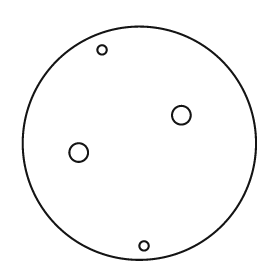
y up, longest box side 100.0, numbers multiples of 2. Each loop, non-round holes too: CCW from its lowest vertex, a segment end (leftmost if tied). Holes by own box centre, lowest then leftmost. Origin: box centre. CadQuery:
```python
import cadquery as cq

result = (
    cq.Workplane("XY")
    .moveTo(0.0, 0.0)
    .circle(50.0)
    .moveTo(2.0, -44.0)
    .circle(2.0)
    .moveTo(-26.0, -4.0)
    .circle(4.0)
    .moveTo(18.0, 12.0)
    .circle(4.0)
    .moveTo(-16.0, 40.0)
    .circle(2.0)
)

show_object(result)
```